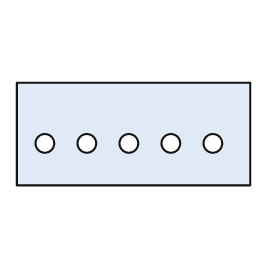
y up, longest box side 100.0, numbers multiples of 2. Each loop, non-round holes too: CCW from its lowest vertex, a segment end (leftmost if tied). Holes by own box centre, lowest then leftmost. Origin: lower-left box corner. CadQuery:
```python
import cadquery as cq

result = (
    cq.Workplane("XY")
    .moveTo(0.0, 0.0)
    .lineTo(100.0, 0.0)
    .lineTo(100.0, 44.0)
    .lineTo(0.0, 44.0)
    .close()
    .moveTo(12.0, 18.0)
    .circle(4.0)
    .moveTo(30.0, 18.0)
    .circle(4.0)
    .moveTo(48.0, 18.0)
    .circle(4.0)
    .moveTo(66.0, 18.0)
    .circle(4.0)
    .moveTo(84.0, 18.0)
    .circle(4.0)
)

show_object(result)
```